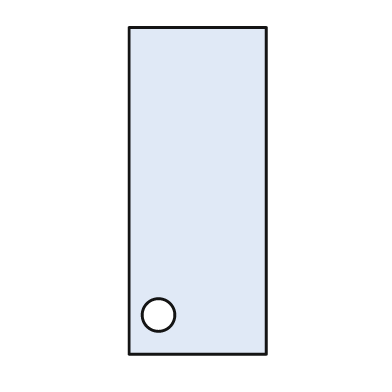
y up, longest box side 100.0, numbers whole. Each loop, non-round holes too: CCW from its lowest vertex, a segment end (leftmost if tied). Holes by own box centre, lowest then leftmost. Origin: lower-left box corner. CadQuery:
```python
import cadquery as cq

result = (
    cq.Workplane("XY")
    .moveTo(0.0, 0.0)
    .lineTo(42.0, 0.0)
    .lineTo(42.0, 100.0)
    .lineTo(0.0, 100.0)
    .close()
    .moveTo(9.0, 12.0)
    .circle(5.0)
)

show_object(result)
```